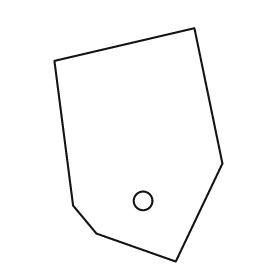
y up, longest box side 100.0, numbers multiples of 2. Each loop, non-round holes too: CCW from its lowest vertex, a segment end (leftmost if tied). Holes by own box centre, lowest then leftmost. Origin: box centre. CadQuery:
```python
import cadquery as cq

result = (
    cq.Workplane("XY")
    .moveTo(16.0, -50.0)
    .lineTo(36.0, -8.0)
    .lineTo(24.0, 50.0)
    .lineTo(-36.0, 36.0)
    .lineTo(-28.0, -26.0)
    .lineTo(-18.0, -38.0)
    .close()
    .moveTo(2.0, -24.0)
    .circle(4.0)
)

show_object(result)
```